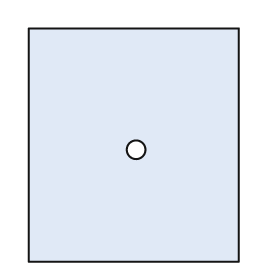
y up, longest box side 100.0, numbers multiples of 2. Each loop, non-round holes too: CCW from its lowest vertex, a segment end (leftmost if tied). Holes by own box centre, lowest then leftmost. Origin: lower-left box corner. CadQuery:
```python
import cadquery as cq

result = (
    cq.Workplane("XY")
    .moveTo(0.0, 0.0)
    .lineTo(90.0, 0.0)
    .lineTo(90.0, 100.0)
    .lineTo(0.0, 100.0)
    .close()
    .moveTo(46.0, 48.0)
    .circle(4.0)
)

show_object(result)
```